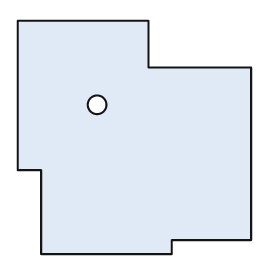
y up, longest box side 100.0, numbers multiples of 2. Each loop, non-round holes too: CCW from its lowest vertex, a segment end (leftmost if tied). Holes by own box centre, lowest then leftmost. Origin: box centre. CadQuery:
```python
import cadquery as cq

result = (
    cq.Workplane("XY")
    .moveTo(-40.0, -50.0)
    .lineTo(16.0, -50.0)
    .lineTo(16.0, -44.0)
    .lineTo(50.0, -44.0)
    .lineTo(50.0, 30.0)
    .lineTo(6.0, 30.0)
    .lineTo(6.0, 50.0)
    .lineTo(-50.0, 50.0)
    .lineTo(-50.0, -14.0)
    .lineTo(-40.0, -14.0)
    .close()
    .moveTo(-16.0, 14.0)
    .circle(4.0)
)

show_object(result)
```